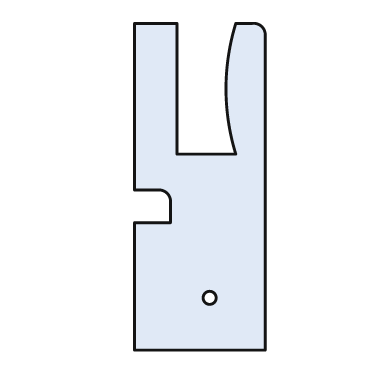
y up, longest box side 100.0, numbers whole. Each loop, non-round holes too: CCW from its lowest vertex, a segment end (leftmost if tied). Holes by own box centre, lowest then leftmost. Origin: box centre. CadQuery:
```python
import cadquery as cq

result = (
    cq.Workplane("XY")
    .moveTo(-20.0, -50.0)
    .lineTo(20.0, -50.0)
    .lineTo(20.0, 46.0)
    .threePointArc((19.0, 49.0), (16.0, 50.0))
    .lineTo(11.0, 50.0)
    .threePointArc((8.0, 30.0), (11.0, 10.0))
    .lineTo(-7.0, 10.0)
    .lineTo(-7.0, 50.0)
    .lineTo(-20.0, 50.0)
    .lineTo(-20.0, -1.0)
    .lineTo(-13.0, -1.0)
    .threePointArc((-10.0, -2.0), (-9.0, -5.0))
    .lineTo(-9.0, -11.0)
    .lineTo(-20.0, -11.0)
    .close()
    .moveTo(3.0, -34.0)
    .circle(2.0)
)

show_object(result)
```